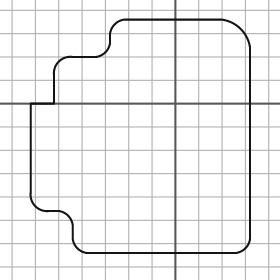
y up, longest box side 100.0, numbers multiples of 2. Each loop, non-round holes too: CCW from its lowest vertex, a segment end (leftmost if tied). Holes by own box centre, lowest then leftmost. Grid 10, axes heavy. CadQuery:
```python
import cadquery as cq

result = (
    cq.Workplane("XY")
    .moveTo(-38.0, -64.0)
    .lineTo(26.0, -64.0)
    .threePointArc((30.0, -62.0), (32.0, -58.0))
    .lineTo(32.0, 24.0)
    .threePointArc((28.0, 32.0), (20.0, 36.0))
    .lineTo(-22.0, 36.0)
    .threePointArc((-26.0, 34.0), (-28.0, 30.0))
    .lineTo(-28.0, 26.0)
    .threePointArc((-30.0, 22.0), (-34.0, 20.0))
    .lineTo(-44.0, 20.0)
    .threePointArc((-50.0, 18.0), (-52.0, 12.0))
    .lineTo(-52.0, 0.0)
    .lineTo(-62.0, 0.0)
    .lineTo(-62.0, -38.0)
    .threePointArc((-60.0, -44.0), (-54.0, -46.0))
    .lineTo(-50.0, -46.0)
    .threePointArc((-46.0, -48.0), (-44.0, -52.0))
    .lineTo(-44.0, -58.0)
    .threePointArc((-42.0, -62.0), (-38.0, -64.0))
    .close()
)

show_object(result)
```